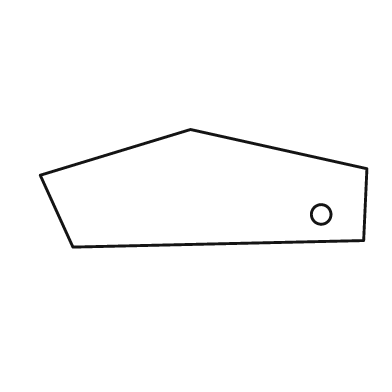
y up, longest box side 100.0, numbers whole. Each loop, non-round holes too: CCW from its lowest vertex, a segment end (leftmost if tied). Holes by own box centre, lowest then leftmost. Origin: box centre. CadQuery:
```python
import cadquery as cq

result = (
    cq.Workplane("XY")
    .moveTo(-40.0, -18.0)
    .lineTo(49.0, -16.0)
    .lineTo(50.0, 6.0)
    .lineTo(-4.0, 18.0)
    .lineTo(-50.0, 4.0)
    .close()
    .moveTo(36.0, -8.0)
    .circle(3.0)
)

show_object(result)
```